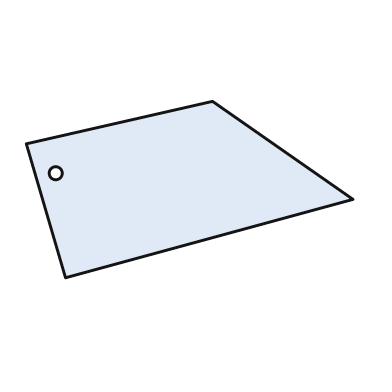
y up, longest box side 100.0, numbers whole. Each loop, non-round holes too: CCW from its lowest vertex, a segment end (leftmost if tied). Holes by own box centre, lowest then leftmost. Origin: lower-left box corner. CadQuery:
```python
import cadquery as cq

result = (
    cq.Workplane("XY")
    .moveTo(12.0, 0.0)
    .lineTo(100.0, 24.0)
    .lineTo(57.0, 54.0)
    .lineTo(0.0, 41.0)
    .close()
    .moveTo(9.0, 32.0)
    .circle(2.0)
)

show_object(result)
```